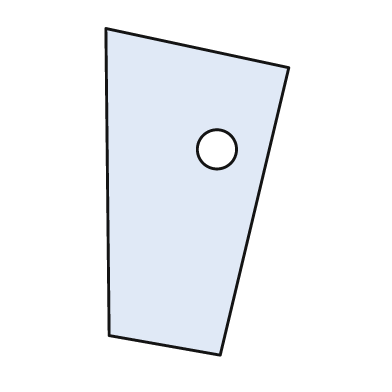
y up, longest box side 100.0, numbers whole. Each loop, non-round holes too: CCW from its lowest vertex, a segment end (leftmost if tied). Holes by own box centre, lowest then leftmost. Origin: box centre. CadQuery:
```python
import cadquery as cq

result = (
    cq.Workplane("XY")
    .moveTo(7.0, -50.0)
    .lineTo(28.0, 38.0)
    .lineTo(-28.0, 50.0)
    .lineTo(-27.0, -44.0)
    .close()
    .moveTo(6.0, 13.0)
    .circle(6.0)
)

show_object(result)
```